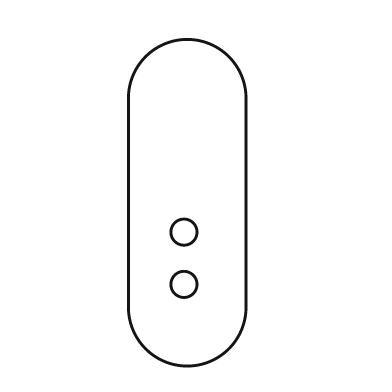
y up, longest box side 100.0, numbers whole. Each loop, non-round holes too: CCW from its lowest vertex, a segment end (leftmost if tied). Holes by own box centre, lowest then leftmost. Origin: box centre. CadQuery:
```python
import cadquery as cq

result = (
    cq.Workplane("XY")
    .moveTo(-18.0, -32.0)
    .threePointArc((0.0, -50.0), (18.0, -32.0))
    .lineTo(18.0, 32.0)
    .threePointArc((0.0, 50.0), (-18.0, 32.0))
    .close()
    .moveTo(-1.0, -25.0)
    .circle(4.0)
    .moveTo(-1.0, -9.0)
    .circle(4.0)
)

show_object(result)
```